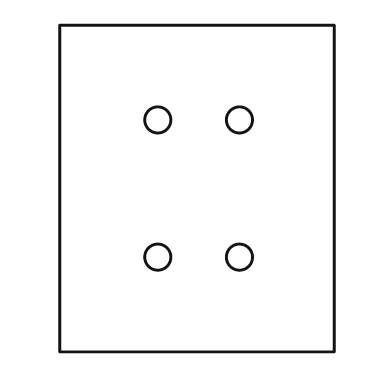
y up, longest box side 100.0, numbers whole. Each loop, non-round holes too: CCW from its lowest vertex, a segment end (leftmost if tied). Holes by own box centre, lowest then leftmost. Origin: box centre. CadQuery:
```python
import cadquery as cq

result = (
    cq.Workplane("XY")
    .moveTo(-42.0, -50.0)
    .lineTo(42.0, -50.0)
    .lineTo(42.0, 50.0)
    .lineTo(-42.0, 50.0)
    .close()
    .moveTo(-12.0, -21.0)
    .circle(4.0)
    .moveTo(13.0, -21.0)
    .circle(4.0)
    .moveTo(-12.0, 21.0)
    .circle(4.0)
    .moveTo(13.0, 21.0)
    .circle(4.0)
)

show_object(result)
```